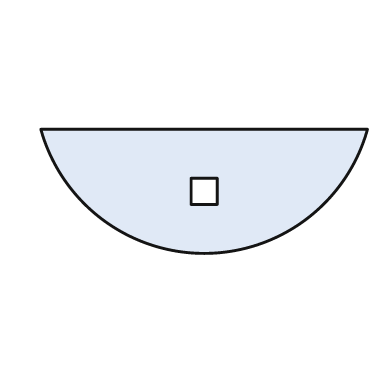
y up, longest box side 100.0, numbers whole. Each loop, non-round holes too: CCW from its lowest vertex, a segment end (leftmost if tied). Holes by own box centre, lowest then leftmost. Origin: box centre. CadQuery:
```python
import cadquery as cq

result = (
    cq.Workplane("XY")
    .moveTo(-50.0, 19.0)
    .threePointArc((0.0, -19.0), (50.0, 19.0))
    .close()
    .moveTo(-4.0, -4.0)
    .lineTo(4.0, -4.0)
    .lineTo(4.0, 4.0)
    .lineTo(-4.0, 4.0)
    .close()
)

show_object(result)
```